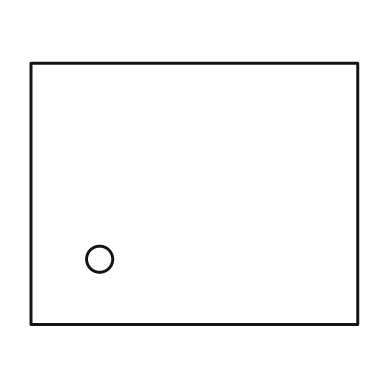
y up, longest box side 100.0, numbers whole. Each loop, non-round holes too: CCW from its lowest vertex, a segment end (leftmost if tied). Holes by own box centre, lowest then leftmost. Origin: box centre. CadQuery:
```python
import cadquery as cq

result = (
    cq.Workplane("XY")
    .moveTo(-50.0, -40.0)
    .lineTo(50.0, -40.0)
    .lineTo(50.0, 40.0)
    .lineTo(-50.0, 40.0)
    .close()
    .moveTo(-29.0, -20.0)
    .circle(4.0)
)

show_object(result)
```